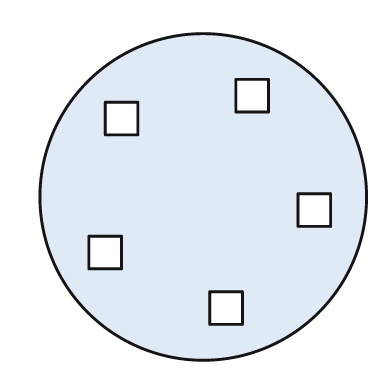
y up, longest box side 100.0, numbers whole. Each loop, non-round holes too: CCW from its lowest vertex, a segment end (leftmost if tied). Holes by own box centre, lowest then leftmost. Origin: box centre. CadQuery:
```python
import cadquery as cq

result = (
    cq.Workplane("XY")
    .moveTo(0.0, 0.0)
    .circle(50.0)
    .moveTo(2.0, -39.0)
    .lineTo(12.0, -39.0)
    .lineTo(12.0, -29.0)
    .lineTo(2.0, -29.0)
    .close()
    .moveTo(-35.0, -22.0)
    .lineTo(-25.0, -22.0)
    .lineTo(-25.0, -12.0)
    .lineTo(-35.0, -12.0)
    .close()
    .moveTo(29.0, -9.0)
    .lineTo(39.0, -9.0)
    .lineTo(39.0, 1.0)
    .lineTo(29.0, 1.0)
    .close()
    .moveTo(-30.0, 19.0)
    .lineTo(-20.0, 19.0)
    .lineTo(-20.0, 29.0)
    .lineTo(-30.0, 29.0)
    .close()
    .moveTo(10.0, 26.0)
    .lineTo(20.0, 26.0)
    .lineTo(20.0, 36.0)
    .lineTo(10.0, 36.0)
    .close()
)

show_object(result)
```